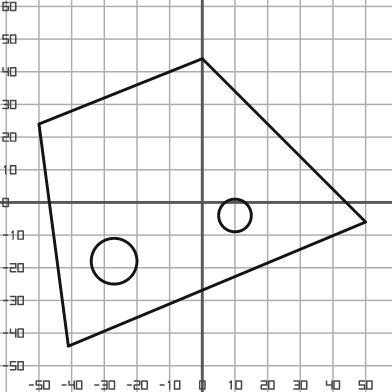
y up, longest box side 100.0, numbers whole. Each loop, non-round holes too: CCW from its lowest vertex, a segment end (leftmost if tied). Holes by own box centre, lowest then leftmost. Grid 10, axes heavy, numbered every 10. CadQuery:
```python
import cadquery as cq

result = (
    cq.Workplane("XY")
    .moveTo(-41.0, -44.0)
    .lineTo(50.0, -6.0)
    .lineTo(0.0, 44.0)
    .lineTo(-50.0, 24.0)
    .close()
    .moveTo(-27.0, -18.0)
    .circle(7.0)
    .moveTo(10.0, -4.0)
    .circle(5.0)
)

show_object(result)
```